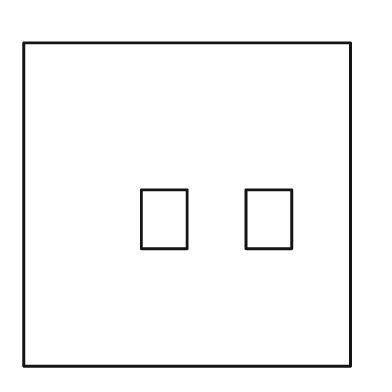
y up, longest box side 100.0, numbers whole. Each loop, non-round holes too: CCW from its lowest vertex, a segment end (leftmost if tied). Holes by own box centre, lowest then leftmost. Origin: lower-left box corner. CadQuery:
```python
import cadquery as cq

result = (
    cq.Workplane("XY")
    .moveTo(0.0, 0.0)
    .lineTo(100.0, 0.0)
    .lineTo(100.0, 99.0)
    .lineTo(0.0, 99.0)
    .close()
    .moveTo(36.0, 36.0)
    .lineTo(50.0, 36.0)
    .lineTo(50.0, 54.0)
    .lineTo(36.0, 54.0)
    .close()
    .moveTo(68.0, 36.0)
    .lineTo(82.0, 36.0)
    .lineTo(82.0, 54.0)
    .lineTo(68.0, 54.0)
    .close()
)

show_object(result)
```